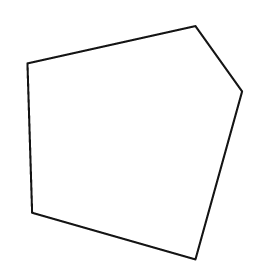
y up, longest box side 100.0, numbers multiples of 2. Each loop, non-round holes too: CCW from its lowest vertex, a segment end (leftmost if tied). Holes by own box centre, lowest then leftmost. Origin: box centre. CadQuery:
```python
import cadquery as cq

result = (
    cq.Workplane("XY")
    .moveTo(26.0, -50.0)
    .lineTo(46.0, 22.0)
    .lineTo(26.0, 50.0)
    .lineTo(-46.0, 34.0)
    .lineTo(-44.0, -30.0)
    .close()
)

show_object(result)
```